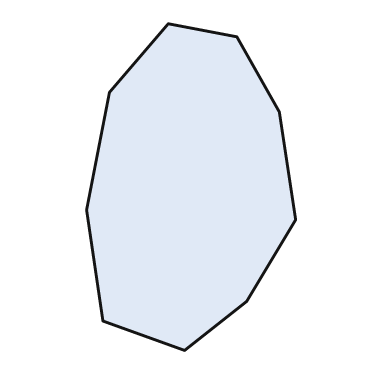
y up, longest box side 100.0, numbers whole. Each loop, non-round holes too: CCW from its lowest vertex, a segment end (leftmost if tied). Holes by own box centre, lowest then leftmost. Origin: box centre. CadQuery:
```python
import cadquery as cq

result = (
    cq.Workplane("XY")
    .moveTo(-2.0, -50.0)
    .lineTo(17.0, -35.0)
    .lineTo(32.0, -10.0)
    .lineTo(27.0, 23.0)
    .lineTo(14.0, 46.0)
    .lineTo(-7.0, 50.0)
    .lineTo(-25.0, 29.0)
    .lineTo(-32.0, -7.0)
    .lineTo(-27.0, -41.0)
    .close()
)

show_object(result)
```